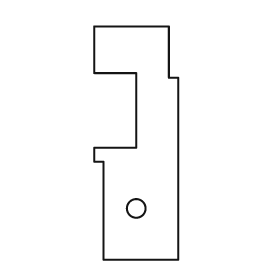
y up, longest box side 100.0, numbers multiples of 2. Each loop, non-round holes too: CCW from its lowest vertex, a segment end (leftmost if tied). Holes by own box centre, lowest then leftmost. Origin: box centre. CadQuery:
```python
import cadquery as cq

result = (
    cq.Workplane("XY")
    .moveTo(-14.0, -50.0)
    .lineTo(18.0, -50.0)
    .lineTo(18.0, 28.0)
    .lineTo(14.0, 28.0)
    .lineTo(14.0, 50.0)
    .lineTo(-18.0, 50.0)
    .lineTo(-18.0, 30.0)
    .lineTo(0.0, 30.0)
    .lineTo(0.0, -2.0)
    .lineTo(-18.0, -2.0)
    .lineTo(-18.0, -8.0)
    .lineTo(-14.0, -8.0)
    .close()
    .moveTo(0.0, -28.0)
    .circle(4.0)
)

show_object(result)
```